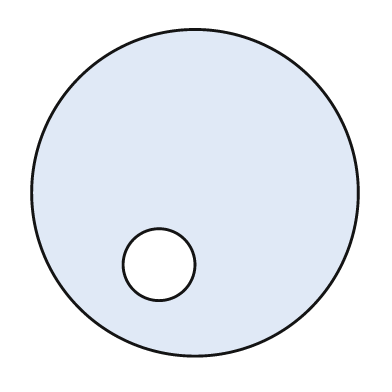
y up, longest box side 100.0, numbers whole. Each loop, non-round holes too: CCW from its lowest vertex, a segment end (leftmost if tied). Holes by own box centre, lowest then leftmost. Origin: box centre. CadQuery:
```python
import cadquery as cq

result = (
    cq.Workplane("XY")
    .moveTo(0.0, 0.0)
    .circle(50.0)
    .moveTo(-11.0, -22.0)
    .circle(11.0)
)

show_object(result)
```